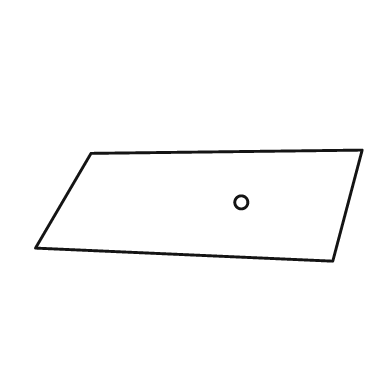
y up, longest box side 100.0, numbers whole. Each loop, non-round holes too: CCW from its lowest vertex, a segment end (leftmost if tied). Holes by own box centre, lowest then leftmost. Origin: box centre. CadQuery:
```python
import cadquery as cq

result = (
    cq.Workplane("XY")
    .moveTo(41.0, -17.0)
    .lineTo(50.0, 17.0)
    .lineTo(-33.0, 16.0)
    .lineTo(-50.0, -13.0)
    .close()
    .moveTo(13.0, 1.0)
    .circle(2.0)
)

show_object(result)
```